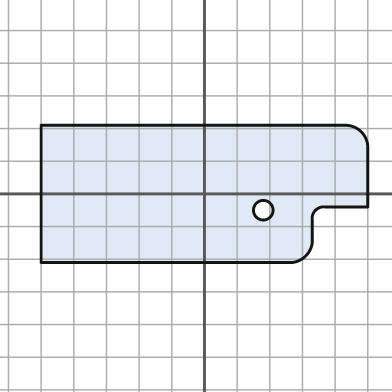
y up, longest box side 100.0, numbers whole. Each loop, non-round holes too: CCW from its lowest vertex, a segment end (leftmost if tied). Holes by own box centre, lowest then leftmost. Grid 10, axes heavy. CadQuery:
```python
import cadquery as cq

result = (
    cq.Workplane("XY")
    .moveTo(-50.0, -21.0)
    .lineTo(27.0, -21.0)
    .threePointArc((31.0, -19.0), (33.0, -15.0))
    .lineTo(33.0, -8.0)
    .threePointArc((34.0, -5.0), (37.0, -4.0))
    .lineTo(50.0, -4.0)
    .lineTo(50.0, 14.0)
    .threePointArc((48.0, 19.0), (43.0, 21.0))
    .lineTo(-50.0, 21.0)
    .close()
    .moveTo(18.0, -5.0)
    .circle(3.0)
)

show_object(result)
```